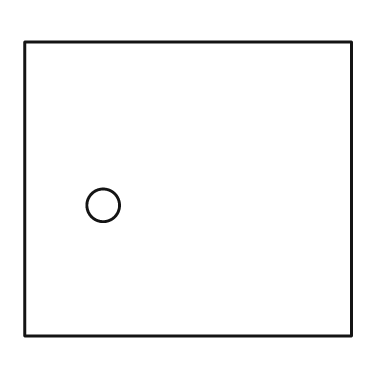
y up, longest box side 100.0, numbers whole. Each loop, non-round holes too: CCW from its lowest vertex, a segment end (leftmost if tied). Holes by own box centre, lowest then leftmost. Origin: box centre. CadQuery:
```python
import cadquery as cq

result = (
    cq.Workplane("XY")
    .moveTo(-50.0, -45.0)
    .lineTo(50.0, -45.0)
    .lineTo(50.0, 45.0)
    .lineTo(-50.0, 45.0)
    .close()
    .moveTo(-26.0, -5.0)
    .circle(5.0)
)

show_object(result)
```